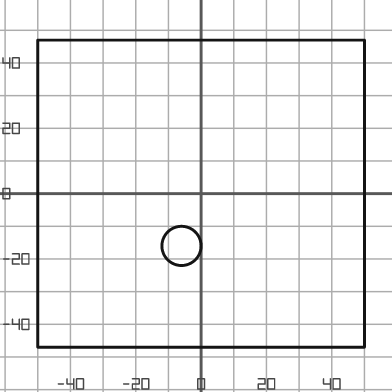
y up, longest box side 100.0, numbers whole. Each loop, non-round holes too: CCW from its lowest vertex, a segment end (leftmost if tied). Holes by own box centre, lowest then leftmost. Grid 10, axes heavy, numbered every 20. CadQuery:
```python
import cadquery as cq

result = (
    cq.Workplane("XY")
    .moveTo(-50.0, -47.0)
    .lineTo(50.0, -47.0)
    .lineTo(50.0, 47.0)
    .lineTo(-50.0, 47.0)
    .close()
    .moveTo(-6.0, -16.0)
    .circle(6.0)
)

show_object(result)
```